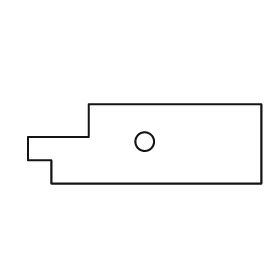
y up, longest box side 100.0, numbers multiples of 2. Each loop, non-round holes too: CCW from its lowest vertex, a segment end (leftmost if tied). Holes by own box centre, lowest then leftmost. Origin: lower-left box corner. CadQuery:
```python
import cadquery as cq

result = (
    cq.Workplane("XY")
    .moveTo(10.0, 0.0)
    .lineTo(100.0, 0.0)
    .lineTo(100.0, 34.0)
    .lineTo(26.0, 34.0)
    .lineTo(26.0, 20.0)
    .lineTo(0.0, 20.0)
    .lineTo(0.0, 10.0)
    .lineTo(10.0, 10.0)
    .close()
    .moveTo(50.0, 18.0)
    .circle(4.0)
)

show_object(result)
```